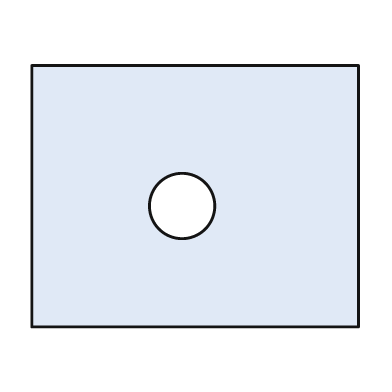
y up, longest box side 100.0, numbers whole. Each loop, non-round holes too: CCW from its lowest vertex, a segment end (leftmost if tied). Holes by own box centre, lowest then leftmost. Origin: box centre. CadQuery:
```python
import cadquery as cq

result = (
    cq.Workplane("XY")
    .moveTo(-50.0, -40.0)
    .lineTo(50.0, -40.0)
    .lineTo(50.0, 40.0)
    .lineTo(-50.0, 40.0)
    .close()
    .moveTo(-4.0, -3.0)
    .circle(10.0)
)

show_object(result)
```